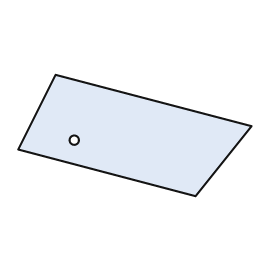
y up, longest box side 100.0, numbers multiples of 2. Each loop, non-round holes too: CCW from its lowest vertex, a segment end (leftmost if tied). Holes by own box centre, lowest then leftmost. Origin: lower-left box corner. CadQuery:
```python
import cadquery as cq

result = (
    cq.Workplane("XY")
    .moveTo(76.0, 0.0)
    .lineTo(100.0, 30.0)
    .lineTo(16.0, 52.0)
    .lineTo(0.0, 20.0)
    .close()
    .moveTo(24.0, 24.0)
    .circle(2.0)
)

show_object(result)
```